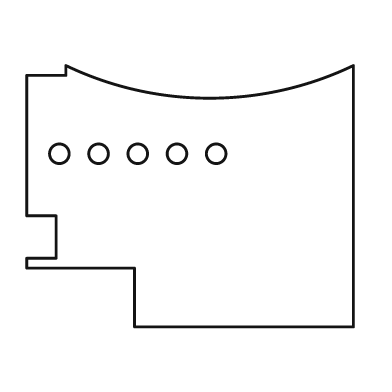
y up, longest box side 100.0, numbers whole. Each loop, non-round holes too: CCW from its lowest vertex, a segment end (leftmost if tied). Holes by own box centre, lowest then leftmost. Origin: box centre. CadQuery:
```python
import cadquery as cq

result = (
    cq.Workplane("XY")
    .moveTo(-17.0, -40.0)
    .lineTo(50.0, -40.0)
    .lineTo(50.0, 40.0)
    .threePointArc((6.0, 30.0), (-38.0, 40.0))
    .lineTo(-38.0, 37.0)
    .lineTo(-50.0, 37.0)
    .lineTo(-50.0, -6.0)
    .lineTo(-41.0, -6.0)
    .lineTo(-41.0, -19.0)
    .lineTo(-50.0, -19.0)
    .lineTo(-50.0, -22.0)
    .lineTo(-17.0, -22.0)
    .close()
    .moveTo(-40.0, 13.0)
    .circle(3.0)
    .moveTo(-28.0, 13.0)
    .circle(3.0)
    .moveTo(-16.0, 13.0)
    .circle(3.0)
    .moveTo(-4.0, 13.0)
    .circle(3.0)
    .moveTo(8.0, 13.0)
    .circle(3.0)
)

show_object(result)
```